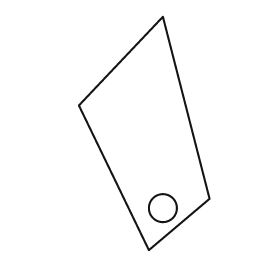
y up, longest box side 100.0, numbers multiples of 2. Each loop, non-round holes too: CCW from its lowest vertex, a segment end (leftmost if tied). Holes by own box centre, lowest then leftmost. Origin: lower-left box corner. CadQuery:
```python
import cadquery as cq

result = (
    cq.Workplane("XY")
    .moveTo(30.0, 0.0)
    .lineTo(56.0, 22.0)
    .lineTo(36.0, 100.0)
    .lineTo(0.0, 62.0)
    .close()
    .moveTo(36.0, 18.0)
    .circle(6.0)
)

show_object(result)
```